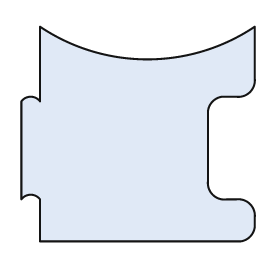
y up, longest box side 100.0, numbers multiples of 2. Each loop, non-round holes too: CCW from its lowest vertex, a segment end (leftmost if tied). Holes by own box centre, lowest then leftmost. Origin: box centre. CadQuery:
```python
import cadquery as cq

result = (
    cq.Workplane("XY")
    .moveTo(-42.0, -46.0)
    .lineTo(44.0, -46.0)
    .threePointArc((48.0, -44.0), (50.0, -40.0))
    .lineTo(50.0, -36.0)
    .threePointArc((48.0, -30.0), (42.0, -28.0))
    .lineTo(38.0, -28.0)
    .threePointArc((32.0, -26.0), (30.0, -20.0))
    .lineTo(30.0, 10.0)
    .threePointArc((32.0, 14.0), (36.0, 16.0))
    .lineTo(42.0, 16.0)
    .threePointArc((48.0, 18.0), (50.0, 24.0))
    .lineTo(50.0, 46.0)
    .threePointArc((4.0, 32.0), (-42.0, 46.0))
    .lineTo(-42.0, 14.0)
    .threePointArc((-46.0, 16.0), (-50.0, 14.0))
    .lineTo(-50.0, -28.0)
    .threePointArc((-46.0, -26.0), (-42.0, -28.0))
    .close()
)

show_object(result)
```